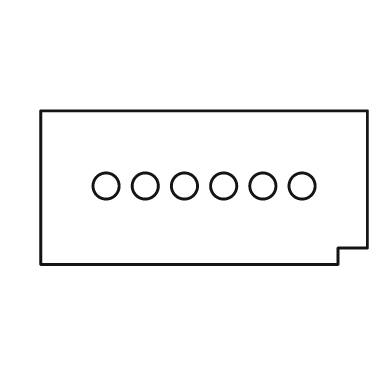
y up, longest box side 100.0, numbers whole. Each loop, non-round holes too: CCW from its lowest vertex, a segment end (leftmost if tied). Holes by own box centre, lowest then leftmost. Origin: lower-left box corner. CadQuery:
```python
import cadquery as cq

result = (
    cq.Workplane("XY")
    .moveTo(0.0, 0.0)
    .lineTo(91.0, 0.0)
    .lineTo(91.0, 5.0)
    .lineTo(100.0, 5.0)
    .lineTo(100.0, 47.0)
    .lineTo(0.0, 47.0)
    .close()
    .moveTo(20.0, 24.0)
    .circle(4.0)
    .moveTo(32.0, 24.0)
    .circle(4.0)
    .moveTo(44.0, 24.0)
    .circle(4.0)
    .moveTo(56.0, 24.0)
    .circle(4.0)
    .moveTo(68.0, 24.0)
    .circle(4.0)
    .moveTo(80.0, 24.0)
    .circle(4.0)
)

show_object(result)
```